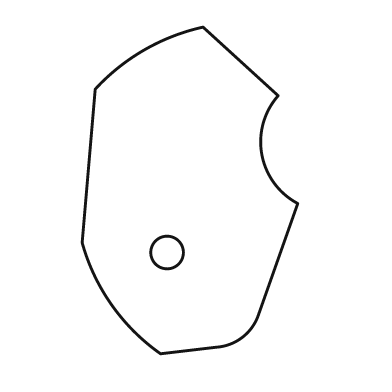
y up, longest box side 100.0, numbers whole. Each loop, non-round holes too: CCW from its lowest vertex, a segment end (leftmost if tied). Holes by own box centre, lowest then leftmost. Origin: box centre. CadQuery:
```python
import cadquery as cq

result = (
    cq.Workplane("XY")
    .moveTo(-9.0, -50.0)
    .lineTo(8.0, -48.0)
    .threePointArc((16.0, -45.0), (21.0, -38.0))
    .lineTo(33.0, -4.0)
    .threePointArc((22.0, 11.0), (27.0, 29.0))
    .lineTo(4.0, 50.0)
    .threePointArc((-14.0, 43.0), (-29.0, 31.0))
    .lineTo(-33.0, -16.0)
    .threePointArc((-24.0, -35.0), (-9.0, -50.0))
    .close()
    .moveTo(-7.0, -19.0)
    .circle(5.0)
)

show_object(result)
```